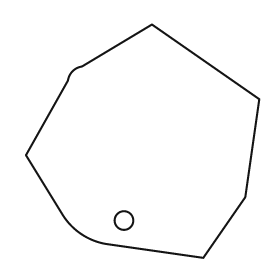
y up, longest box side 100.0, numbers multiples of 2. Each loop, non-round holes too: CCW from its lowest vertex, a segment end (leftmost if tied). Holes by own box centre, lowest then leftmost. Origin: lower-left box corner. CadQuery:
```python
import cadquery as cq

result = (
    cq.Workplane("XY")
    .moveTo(76.0, 0.0)
    .lineTo(94.0, 26.0)
    .lineTo(100.0, 68.0)
    .lineTo(54.0, 100.0)
    .lineTo(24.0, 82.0)
    .threePointArc((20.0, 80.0), (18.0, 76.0))
    .lineTo(0.0, 44.0)
    .lineTo(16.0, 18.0)
    .threePointArc((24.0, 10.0), (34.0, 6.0))
    .close()
    .moveTo(42.0, 16.0)
    .circle(4.0)
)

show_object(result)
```